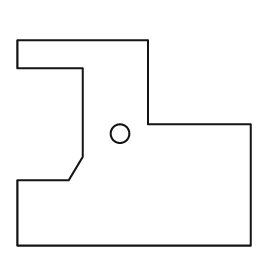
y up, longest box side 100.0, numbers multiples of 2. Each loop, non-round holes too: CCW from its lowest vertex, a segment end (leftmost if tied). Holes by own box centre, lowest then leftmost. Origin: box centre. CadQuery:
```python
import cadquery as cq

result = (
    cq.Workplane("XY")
    .moveTo(-50.0, -44.0)
    .lineTo(50.0, -44.0)
    .lineTo(50.0, 8.0)
    .lineTo(6.0, 8.0)
    .lineTo(6.0, 44.0)
    .lineTo(-50.0, 44.0)
    .lineTo(-50.0, 32.0)
    .lineTo(-22.0, 32.0)
    .lineTo(-22.0, -6.0)
    .lineTo(-28.0, -16.0)
    .lineTo(-50.0, -16.0)
    .close()
    .moveTo(-6.0, 4.0)
    .circle(4.0)
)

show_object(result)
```